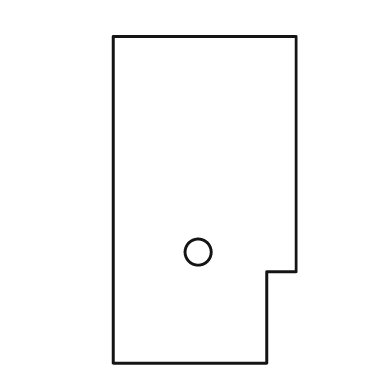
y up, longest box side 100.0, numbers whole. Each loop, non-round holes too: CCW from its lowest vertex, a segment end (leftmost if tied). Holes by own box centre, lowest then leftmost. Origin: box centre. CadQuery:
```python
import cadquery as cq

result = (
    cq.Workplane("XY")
    .moveTo(-28.0, -50.0)
    .lineTo(19.0, -50.0)
    .lineTo(19.0, -22.0)
    .lineTo(28.0, -22.0)
    .lineTo(28.0, 50.0)
    .lineTo(-28.0, 50.0)
    .close()
    .moveTo(-2.0, -16.0)
    .circle(4.0)
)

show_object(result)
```